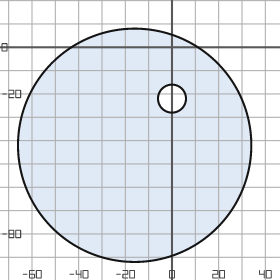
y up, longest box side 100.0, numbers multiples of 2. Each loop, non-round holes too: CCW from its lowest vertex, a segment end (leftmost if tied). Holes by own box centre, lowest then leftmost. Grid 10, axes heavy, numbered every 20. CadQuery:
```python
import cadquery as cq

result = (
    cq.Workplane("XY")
    .moveTo(-16.0, -42.0)
    .circle(50.0)
    .moveTo(0.0, -22.0)
    .circle(6.0)
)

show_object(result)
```